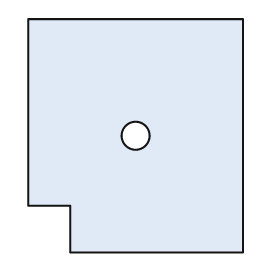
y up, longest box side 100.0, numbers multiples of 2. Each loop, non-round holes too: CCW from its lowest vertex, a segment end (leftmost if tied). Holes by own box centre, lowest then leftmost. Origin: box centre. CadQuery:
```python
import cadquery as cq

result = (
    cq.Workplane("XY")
    .moveTo(-28.0, -50.0)
    .lineTo(46.0, -50.0)
    .lineTo(46.0, 50.0)
    .lineTo(-46.0, 50.0)
    .lineTo(-46.0, -30.0)
    .lineTo(-28.0, -30.0)
    .close()
    .moveTo(0.0, 0.0)
    .circle(6.0)
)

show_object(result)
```